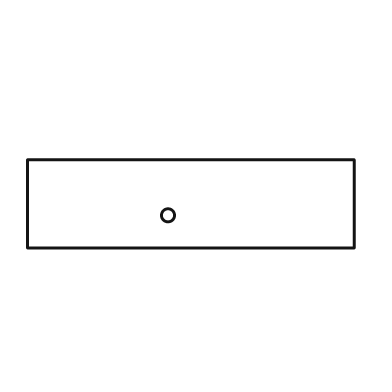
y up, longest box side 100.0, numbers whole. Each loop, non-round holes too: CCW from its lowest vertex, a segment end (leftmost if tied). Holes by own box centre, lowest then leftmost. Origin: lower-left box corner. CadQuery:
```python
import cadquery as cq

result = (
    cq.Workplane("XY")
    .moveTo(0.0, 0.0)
    .lineTo(100.0, 0.0)
    .lineTo(100.0, 27.0)
    .lineTo(0.0, 27.0)
    .close()
    .moveTo(43.0, 10.0)
    .circle(2.0)
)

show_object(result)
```